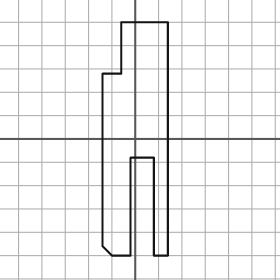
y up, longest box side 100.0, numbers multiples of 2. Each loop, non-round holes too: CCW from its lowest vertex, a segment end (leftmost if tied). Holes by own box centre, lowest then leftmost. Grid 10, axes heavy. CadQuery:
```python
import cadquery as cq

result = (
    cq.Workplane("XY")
    .moveTo(-10.0, -50.0)
    .lineTo(-2.0, -50.0)
    .lineTo(-2.0, -8.0)
    .lineTo(8.0, -8.0)
    .lineTo(8.0, -50.0)
    .lineTo(14.0, -50.0)
    .lineTo(14.0, 50.0)
    .lineTo(-6.0, 50.0)
    .lineTo(-6.0, 28.0)
    .lineTo(-14.0, 28.0)
    .lineTo(-14.0, -46.0)
    .close()
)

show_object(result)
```